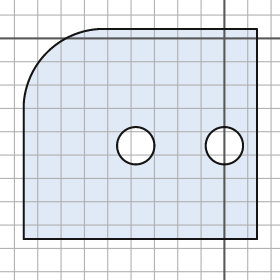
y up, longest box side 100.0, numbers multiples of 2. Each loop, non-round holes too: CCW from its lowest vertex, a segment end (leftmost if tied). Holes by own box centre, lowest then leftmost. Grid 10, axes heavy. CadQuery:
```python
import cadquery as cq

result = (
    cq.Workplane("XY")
    .moveTo(-86.0, -86.0)
    .lineTo(14.0, -86.0)
    .lineTo(14.0, 4.0)
    .lineTo(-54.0, 4.0)
    .threePointArc((-76.0, -6.0), (-86.0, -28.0))
    .close()
    .moveTo(-38.0, -46.0)
    .circle(8.0)
    .moveTo(0.0, -46.0)
    .circle(8.0)
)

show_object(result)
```